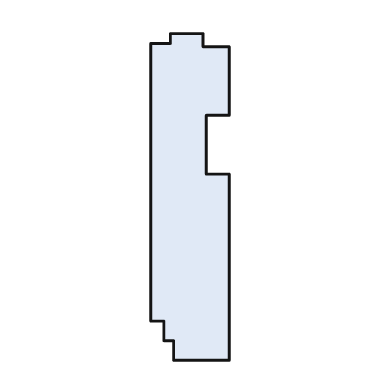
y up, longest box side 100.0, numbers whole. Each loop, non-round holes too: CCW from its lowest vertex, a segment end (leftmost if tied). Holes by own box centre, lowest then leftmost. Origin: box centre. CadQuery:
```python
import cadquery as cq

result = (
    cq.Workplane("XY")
    .moveTo(-5.0, -50.0)
    .lineTo(12.0, -50.0)
    .lineTo(12.0, 7.0)
    .lineTo(5.0, 7.0)
    .lineTo(5.0, 25.0)
    .lineTo(12.0, 25.0)
    .lineTo(12.0, 46.0)
    .lineTo(4.0, 46.0)
    .lineTo(4.0, 50.0)
    .lineTo(-6.0, 50.0)
    .lineTo(-6.0, 47.0)
    .lineTo(-12.0, 47.0)
    .lineTo(-12.0, -38.0)
    .lineTo(-8.0, -38.0)
    .lineTo(-8.0, -44.0)
    .lineTo(-5.0, -44.0)
    .close()
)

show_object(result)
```